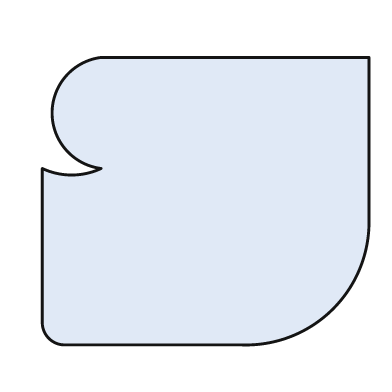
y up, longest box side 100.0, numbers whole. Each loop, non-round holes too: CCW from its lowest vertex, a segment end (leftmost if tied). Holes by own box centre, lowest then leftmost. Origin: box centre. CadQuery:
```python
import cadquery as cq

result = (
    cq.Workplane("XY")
    .moveTo(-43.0, -44.0)
    .lineTo(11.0, -44.0)
    .threePointArc((39.0, -33.0), (50.0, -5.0))
    .lineTo(50.0, 44.0)
    .lineTo(-32.0, 44.0)
    .threePointArc((-47.0, 27.0), (-32.0, 10.0))
    .threePointArc((-41.0, 8.0), (-50.0, 10.0))
    .lineTo(-50.0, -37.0)
    .threePointArc((-48.0, -42.0), (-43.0, -44.0))
    .close()
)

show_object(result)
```